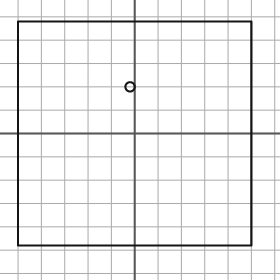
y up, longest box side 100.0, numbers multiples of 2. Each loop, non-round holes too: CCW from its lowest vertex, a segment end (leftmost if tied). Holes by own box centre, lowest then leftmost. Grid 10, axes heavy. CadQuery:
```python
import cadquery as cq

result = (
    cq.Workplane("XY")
    .moveTo(-50.0, -48.0)
    .lineTo(50.0, -48.0)
    .lineTo(50.0, 48.0)
    .lineTo(-50.0, 48.0)
    .close()
    .moveTo(-2.0, 20.0)
    .circle(2.0)
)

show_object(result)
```